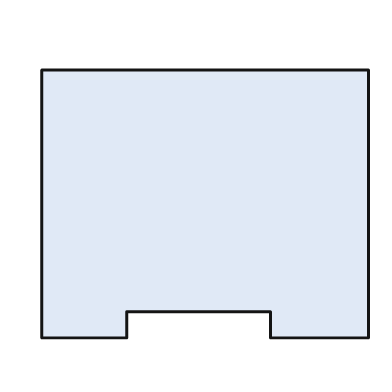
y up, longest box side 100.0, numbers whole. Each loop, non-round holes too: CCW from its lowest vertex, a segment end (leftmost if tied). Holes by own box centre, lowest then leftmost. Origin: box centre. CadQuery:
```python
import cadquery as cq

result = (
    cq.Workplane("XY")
    .moveTo(-50.0, -41.0)
    .lineTo(-24.0, -41.0)
    .lineTo(-24.0, -33.0)
    .lineTo(20.0, -33.0)
    .lineTo(20.0, -41.0)
    .lineTo(50.0, -41.0)
    .lineTo(50.0, 41.0)
    .lineTo(-50.0, 41.0)
    .close()
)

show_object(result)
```